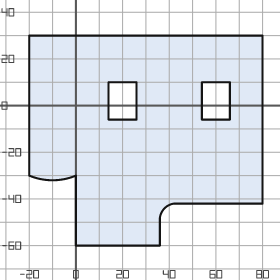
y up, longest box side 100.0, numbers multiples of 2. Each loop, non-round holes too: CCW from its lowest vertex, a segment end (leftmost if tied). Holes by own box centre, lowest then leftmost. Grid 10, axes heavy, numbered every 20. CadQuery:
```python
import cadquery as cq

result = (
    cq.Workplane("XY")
    .moveTo(0.0, -60.0)
    .lineTo(36.0, -60.0)
    .lineTo(36.0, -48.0)
    .threePointArc((38.0, -44.0), (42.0, -42.0))
    .lineTo(80.0, -42.0)
    .lineTo(80.0, 30.0)
    .lineTo(-20.0, 30.0)
    .lineTo(-20.0, -30.0)
    .threePointArc((-10.0, -32.0), (0.0, -30.0))
    .close()
    .moveTo(14.0, -6.0)
    .lineTo(26.0, -6.0)
    .lineTo(26.0, 10.0)
    .lineTo(14.0, 10.0)
    .close()
    .moveTo(54.0, -6.0)
    .lineTo(66.0, -6.0)
    .lineTo(66.0, 10.0)
    .lineTo(54.0, 10.0)
    .close()
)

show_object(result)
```